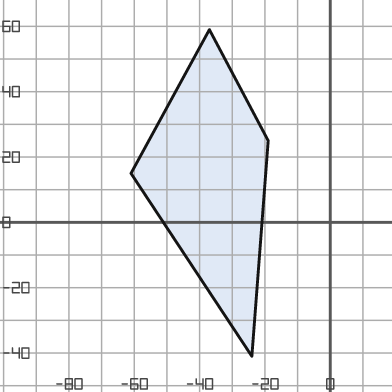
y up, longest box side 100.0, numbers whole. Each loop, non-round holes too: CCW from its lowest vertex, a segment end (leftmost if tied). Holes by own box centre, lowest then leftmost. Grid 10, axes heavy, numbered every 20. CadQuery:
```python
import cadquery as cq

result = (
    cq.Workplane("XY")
    .moveTo(-24.0, -41.0)
    .lineTo(-19.0, 25.0)
    .lineTo(-37.0, 59.0)
    .lineTo(-61.0, 15.0)
    .close()
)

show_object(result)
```